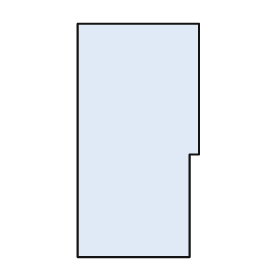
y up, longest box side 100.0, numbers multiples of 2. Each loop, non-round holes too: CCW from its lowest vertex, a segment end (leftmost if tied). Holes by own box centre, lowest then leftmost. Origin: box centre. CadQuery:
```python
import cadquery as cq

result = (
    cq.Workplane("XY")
    .moveTo(-26.0, -50.0)
    .lineTo(22.0, -50.0)
    .lineTo(22.0, -6.0)
    .lineTo(26.0, -6.0)
    .lineTo(26.0, 50.0)
    .lineTo(-26.0, 50.0)
    .close()
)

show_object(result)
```